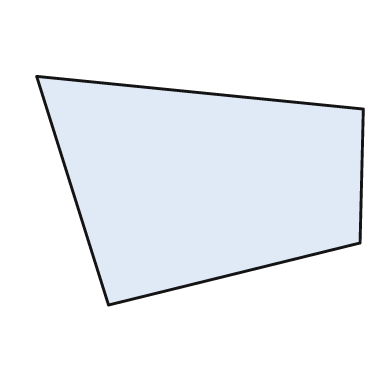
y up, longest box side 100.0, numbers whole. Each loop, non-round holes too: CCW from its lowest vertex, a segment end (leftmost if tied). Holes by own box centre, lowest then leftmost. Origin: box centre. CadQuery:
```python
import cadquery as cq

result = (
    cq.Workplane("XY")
    .moveTo(-28.0, -35.0)
    .lineTo(49.0, -16.0)
    .lineTo(50.0, 25.0)
    .lineTo(-50.0, 35.0)
    .close()
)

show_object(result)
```